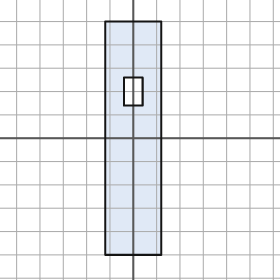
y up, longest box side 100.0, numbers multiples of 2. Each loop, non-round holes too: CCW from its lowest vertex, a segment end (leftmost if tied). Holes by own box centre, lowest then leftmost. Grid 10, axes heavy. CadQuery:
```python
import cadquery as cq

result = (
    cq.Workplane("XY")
    .moveTo(-12.0, -50.0)
    .lineTo(12.0, -50.0)
    .lineTo(12.0, 50.0)
    .lineTo(-12.0, 50.0)
    .close()
    .moveTo(-4.0, 14.0)
    .lineTo(4.0, 14.0)
    .lineTo(4.0, 26.0)
    .lineTo(-4.0, 26.0)
    .close()
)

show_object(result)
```